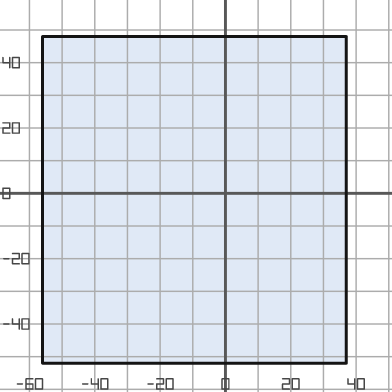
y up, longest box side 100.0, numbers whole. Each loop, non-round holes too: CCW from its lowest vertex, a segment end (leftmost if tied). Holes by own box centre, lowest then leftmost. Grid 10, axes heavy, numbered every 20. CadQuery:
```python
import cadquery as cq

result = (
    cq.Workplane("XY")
    .moveTo(-56.0, -52.0)
    .lineTo(37.0, -52.0)
    .lineTo(37.0, 48.0)
    .lineTo(-56.0, 48.0)
    .close()
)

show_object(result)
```